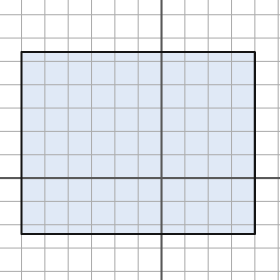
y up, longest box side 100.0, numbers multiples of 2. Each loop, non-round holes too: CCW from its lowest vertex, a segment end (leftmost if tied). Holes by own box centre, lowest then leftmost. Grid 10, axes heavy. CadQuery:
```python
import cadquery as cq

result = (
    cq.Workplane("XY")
    .moveTo(-60.0, -24.0)
    .lineTo(40.0, -24.0)
    .lineTo(40.0, 54.0)
    .lineTo(-60.0, 54.0)
    .close()
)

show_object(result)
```